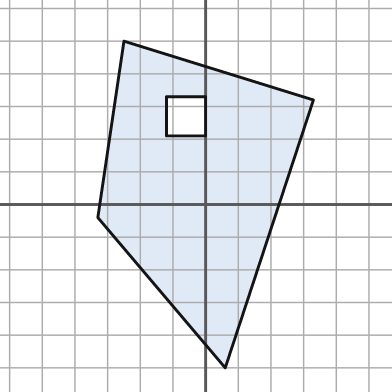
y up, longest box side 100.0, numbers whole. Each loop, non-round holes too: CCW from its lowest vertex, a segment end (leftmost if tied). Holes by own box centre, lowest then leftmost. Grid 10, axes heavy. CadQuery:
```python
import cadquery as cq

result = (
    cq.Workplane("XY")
    .moveTo(6.0, -50.0)
    .lineTo(33.0, 32.0)
    .lineTo(-25.0, 50.0)
    .lineTo(-33.0, -4.0)
    .close()
    .moveTo(-12.0, 21.0)
    .lineTo(0.0, 21.0)
    .lineTo(0.0, 33.0)
    .lineTo(-12.0, 33.0)
    .close()
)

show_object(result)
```